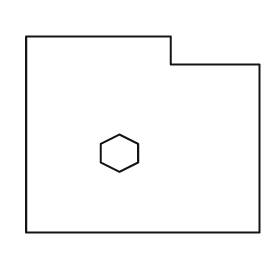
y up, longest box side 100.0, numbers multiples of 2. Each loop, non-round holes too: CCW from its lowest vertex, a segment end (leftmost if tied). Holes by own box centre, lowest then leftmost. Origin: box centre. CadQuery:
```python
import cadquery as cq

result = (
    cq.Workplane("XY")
    .moveTo(-50.0, -42.0)
    .lineTo(50.0, -42.0)
    .lineTo(50.0, 30.0)
    .lineTo(12.0, 30.0)
    .lineTo(12.0, 42.0)
    .lineTo(-50.0, 42.0)
    .close()
    .moveTo(-10.0, -16.0)
    .lineTo(-2.0, -12.0)
    .lineTo(-2.0, -4.0)
    .lineTo(-10.0, 0.0)
    .lineTo(-18.0, -4.0)
    .lineTo(-18.0, -12.0)
    .close()
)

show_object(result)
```